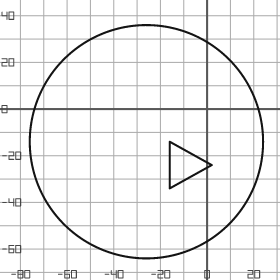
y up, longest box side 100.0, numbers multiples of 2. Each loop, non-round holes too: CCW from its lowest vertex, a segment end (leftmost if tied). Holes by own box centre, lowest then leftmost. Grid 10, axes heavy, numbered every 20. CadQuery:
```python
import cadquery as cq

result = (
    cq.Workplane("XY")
    .moveTo(-26.0, -14.0)
    .circle(50.0)
    .moveTo(-16.0, -34.0)
    .lineTo(2.0, -24.0)
    .lineTo(-16.0, -14.0)
    .close()
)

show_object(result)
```